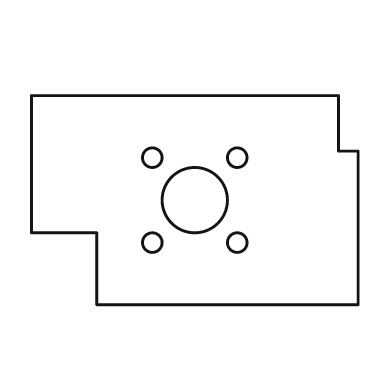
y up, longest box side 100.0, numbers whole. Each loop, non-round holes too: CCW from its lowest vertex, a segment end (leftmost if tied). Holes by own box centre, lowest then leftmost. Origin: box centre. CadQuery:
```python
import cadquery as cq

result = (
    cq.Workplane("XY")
    .moveTo(-30.0, -32.0)
    .lineTo(50.0, -32.0)
    .lineTo(50.0, 15.0)
    .lineTo(44.0, 15.0)
    .lineTo(44.0, 32.0)
    .lineTo(-50.0, 32.0)
    .lineTo(-50.0, -10.0)
    .lineTo(-30.0, -10.0)
    .close()
    .moveTo(-13.0, -13.0)
    .circle(3.0)
    .moveTo(13.0, -13.0)
    .circle(3.0)
    .moveTo(0.0, 0.0)
    .circle(10.0)
    .moveTo(-13.0, 13.0)
    .circle(3.0)
    .moveTo(13.0, 13.0)
    .circle(3.0)
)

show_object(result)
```